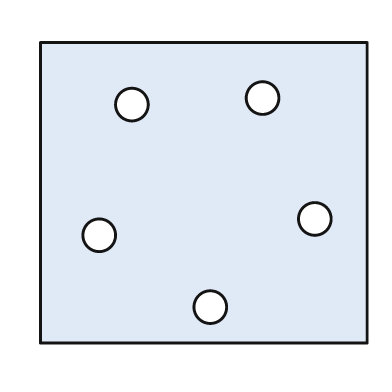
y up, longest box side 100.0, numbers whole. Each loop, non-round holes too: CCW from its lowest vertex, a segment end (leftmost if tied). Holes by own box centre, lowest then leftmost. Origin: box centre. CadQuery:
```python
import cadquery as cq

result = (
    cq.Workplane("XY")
    .moveTo(-50.0, -46.0)
    .lineTo(50.0, -46.0)
    .lineTo(50.0, 46.0)
    .lineTo(-50.0, 46.0)
    .close()
    .moveTo(2.0, -35.0)
    .circle(5.0)
    .moveTo(-32.0, -13.0)
    .circle(5.0)
    .moveTo(34.0, -8.0)
    .circle(5.0)
    .moveTo(-22.0, 27.0)
    .circle(5.0)
    .moveTo(18.0, 29.0)
    .circle(5.0)
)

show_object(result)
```